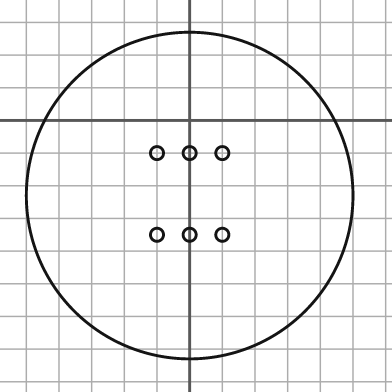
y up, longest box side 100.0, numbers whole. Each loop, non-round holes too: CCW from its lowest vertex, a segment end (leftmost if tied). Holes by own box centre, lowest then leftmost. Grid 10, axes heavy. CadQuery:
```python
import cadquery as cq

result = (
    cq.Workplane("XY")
    .moveTo(0.0, -23.0)
    .circle(50.0)
    .moveTo(-10.0, -35.0)
    .circle(2.0)
    .moveTo(0.0, -35.0)
    .circle(2.0)
    .moveTo(10.0, -35.0)
    .circle(2.0)
    .moveTo(-10.0, -10.0)
    .circle(2.0)
    .moveTo(0.0, -10.0)
    .circle(2.0)
    .moveTo(10.0, -10.0)
    .circle(2.0)
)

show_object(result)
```